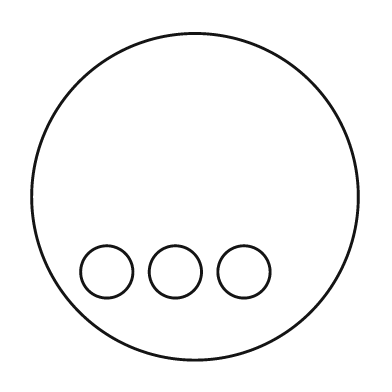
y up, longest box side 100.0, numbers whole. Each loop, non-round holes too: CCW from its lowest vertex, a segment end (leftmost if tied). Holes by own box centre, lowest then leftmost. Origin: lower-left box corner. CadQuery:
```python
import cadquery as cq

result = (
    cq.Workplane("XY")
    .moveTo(50.0, 50.0)
    .circle(50.0)
    .moveTo(23.0, 27.0)
    .circle(8.0)
    .moveTo(44.0, 27.0)
    .circle(8.0)
    .moveTo(65.0, 27.0)
    .circle(8.0)
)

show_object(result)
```